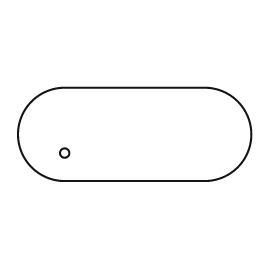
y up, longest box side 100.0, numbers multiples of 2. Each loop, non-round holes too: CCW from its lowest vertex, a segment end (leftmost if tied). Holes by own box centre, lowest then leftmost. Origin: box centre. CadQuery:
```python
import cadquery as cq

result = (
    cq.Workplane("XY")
    .moveTo(-30.0, -20.0)
    .lineTo(30.0, -20.0)
    .threePointArc((50.0, 0.0), (30.0, 20.0))
    .lineTo(-30.0, 20.0)
    .threePointArc((-50.0, 0.0), (-30.0, -20.0))
    .close()
    .moveTo(-30.0, -8.0)
    .circle(2.0)
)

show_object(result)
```